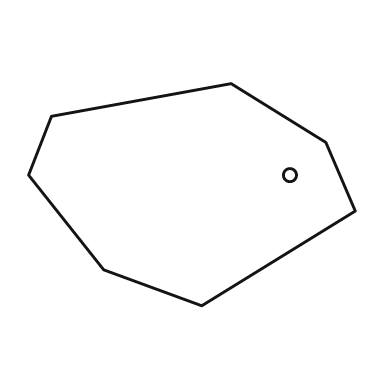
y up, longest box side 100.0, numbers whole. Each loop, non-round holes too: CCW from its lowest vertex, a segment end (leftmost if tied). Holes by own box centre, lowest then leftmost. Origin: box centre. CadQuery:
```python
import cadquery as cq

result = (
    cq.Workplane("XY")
    .moveTo(3.0, -34.0)
    .lineTo(50.0, -5.0)
    .lineTo(41.0, 16.0)
    .lineTo(12.0, 34.0)
    .lineTo(-43.0, 24.0)
    .lineTo(-50.0, 6.0)
    .lineTo(-27.0, -23.0)
    .close()
    .moveTo(30.0, 6.0)
    .circle(2.0)
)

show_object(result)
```